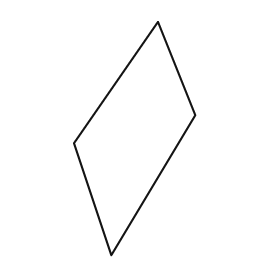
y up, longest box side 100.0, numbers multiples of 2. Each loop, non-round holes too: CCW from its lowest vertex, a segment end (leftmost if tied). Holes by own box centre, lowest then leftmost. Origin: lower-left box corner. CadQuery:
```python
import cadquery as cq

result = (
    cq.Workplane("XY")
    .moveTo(16.0, 0.0)
    .lineTo(52.0, 60.0)
    .lineTo(36.0, 100.0)
    .lineTo(0.0, 48.0)
    .close()
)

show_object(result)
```